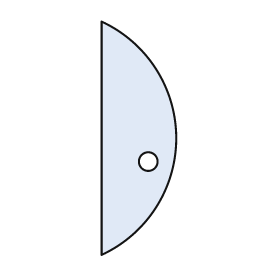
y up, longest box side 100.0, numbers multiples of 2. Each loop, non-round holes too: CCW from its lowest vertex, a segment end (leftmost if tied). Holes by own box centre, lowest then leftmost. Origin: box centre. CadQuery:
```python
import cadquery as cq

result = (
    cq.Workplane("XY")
    .moveTo(-16.0, -50.0)
    .threePointArc((16.0, 0.0), (-16.0, 50.0))
    .close()
    .moveTo(4.0, -10.0)
    .circle(4.0)
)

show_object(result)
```